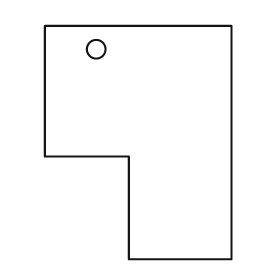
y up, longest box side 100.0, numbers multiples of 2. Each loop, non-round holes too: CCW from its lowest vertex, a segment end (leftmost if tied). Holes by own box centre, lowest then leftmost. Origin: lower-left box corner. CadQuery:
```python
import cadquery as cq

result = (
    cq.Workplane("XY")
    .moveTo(36.0, 0.0)
    .lineTo(80.0, 0.0)
    .lineTo(80.0, 100.0)
    .lineTo(0.0, 100.0)
    .lineTo(0.0, 44.0)
    .lineTo(36.0, 44.0)
    .close()
    .moveTo(22.0, 90.0)
    .circle(4.0)
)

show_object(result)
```